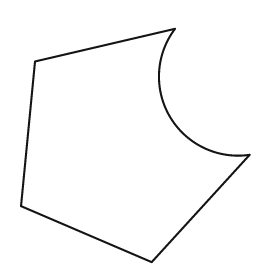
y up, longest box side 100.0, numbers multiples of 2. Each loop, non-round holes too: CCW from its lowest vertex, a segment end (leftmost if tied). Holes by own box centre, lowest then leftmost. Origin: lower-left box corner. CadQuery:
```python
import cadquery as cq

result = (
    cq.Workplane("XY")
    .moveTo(56.0, 0.0)
    .lineTo(98.0, 46.0)
    .threePointArc((64.0, 62.0), (66.0, 100.0))
    .lineTo(6.0, 86.0)
    .lineTo(0.0, 24.0)
    .close()
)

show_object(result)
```